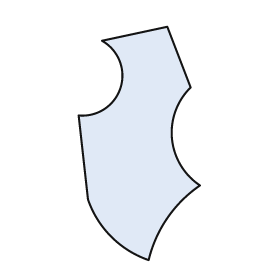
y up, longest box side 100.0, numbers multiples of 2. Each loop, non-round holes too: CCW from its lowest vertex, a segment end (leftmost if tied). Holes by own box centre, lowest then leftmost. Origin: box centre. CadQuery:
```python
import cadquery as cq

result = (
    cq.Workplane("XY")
    .moveTo(4.0, -50.0)
    .threePointArc((12.0, -32.0), (26.0, -18.0))
    .threePointArc((14.0, 2.0), (22.0, 24.0))
    .lineTo(12.0, 50.0)
    .lineTo(-16.0, 44.0)
    .threePointArc((-8.0, 24.0), (-26.0, 12.0))
    .lineTo(-22.0, -24.0)
    .threePointArc((-12.0, -40.0), (4.0, -50.0))
    .close()
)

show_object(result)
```